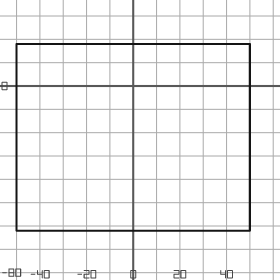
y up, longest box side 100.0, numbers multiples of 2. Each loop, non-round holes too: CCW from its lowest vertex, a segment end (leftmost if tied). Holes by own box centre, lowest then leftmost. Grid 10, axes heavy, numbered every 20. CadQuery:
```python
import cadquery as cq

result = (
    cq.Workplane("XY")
    .moveTo(-50.0, -62.0)
    .lineTo(50.0, -62.0)
    .lineTo(50.0, 18.0)
    .lineTo(-50.0, 18.0)
    .close()
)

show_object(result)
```